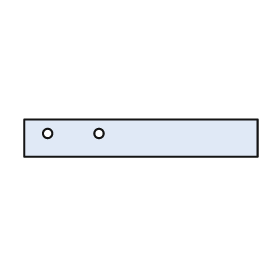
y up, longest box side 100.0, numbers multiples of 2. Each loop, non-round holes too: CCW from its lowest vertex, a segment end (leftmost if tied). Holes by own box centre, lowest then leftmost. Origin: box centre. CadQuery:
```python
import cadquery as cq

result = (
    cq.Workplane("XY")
    .moveTo(-50.0, -8.0)
    .lineTo(50.0, -8.0)
    .lineTo(50.0, 8.0)
    .lineTo(-50.0, 8.0)
    .close()
    .moveTo(-40.0, 2.0)
    .circle(2.0)
    .moveTo(-18.0, 2.0)
    .circle(2.0)
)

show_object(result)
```